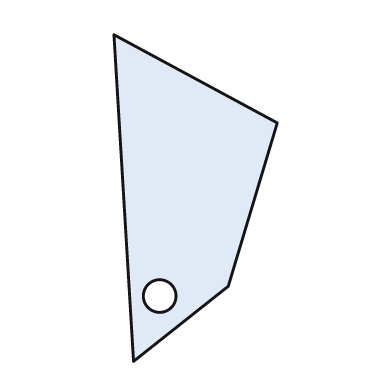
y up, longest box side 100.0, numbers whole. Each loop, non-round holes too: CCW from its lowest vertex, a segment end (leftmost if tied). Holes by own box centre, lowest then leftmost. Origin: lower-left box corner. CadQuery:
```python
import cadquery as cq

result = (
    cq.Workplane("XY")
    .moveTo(6.0, 0.0)
    .lineTo(35.0, 23.0)
    .lineTo(50.0, 73.0)
    .lineTo(0.0, 100.0)
    .close()
    .moveTo(14.0, 20.0)
    .circle(5.0)
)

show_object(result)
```